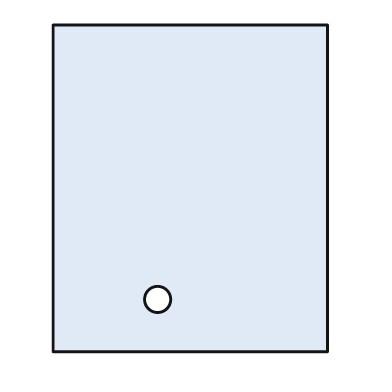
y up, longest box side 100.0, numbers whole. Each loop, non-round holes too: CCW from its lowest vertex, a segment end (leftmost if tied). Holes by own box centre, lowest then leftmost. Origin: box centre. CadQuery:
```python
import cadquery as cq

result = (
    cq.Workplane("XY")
    .moveTo(-42.0, -50.0)
    .lineTo(42.0, -50.0)
    .lineTo(42.0, 50.0)
    .lineTo(-42.0, 50.0)
    .close()
    .moveTo(-10.0, -34.0)
    .circle(4.0)
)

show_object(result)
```